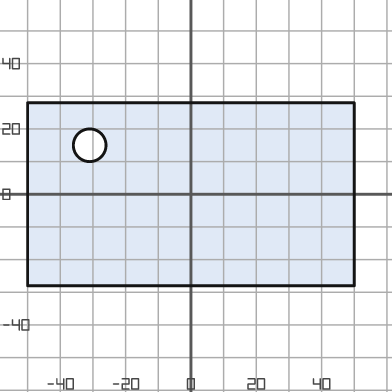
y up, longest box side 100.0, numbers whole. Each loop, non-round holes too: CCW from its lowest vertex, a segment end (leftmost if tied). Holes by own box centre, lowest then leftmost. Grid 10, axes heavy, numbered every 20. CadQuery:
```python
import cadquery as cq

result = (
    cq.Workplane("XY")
    .moveTo(-50.0, -28.0)
    .lineTo(50.0, -28.0)
    .lineTo(50.0, 28.0)
    .lineTo(-50.0, 28.0)
    .close()
    .moveTo(-31.0, 15.0)
    .circle(5.0)
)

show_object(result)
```